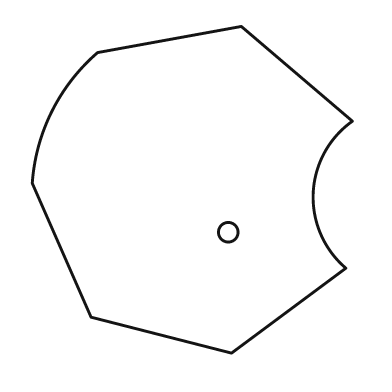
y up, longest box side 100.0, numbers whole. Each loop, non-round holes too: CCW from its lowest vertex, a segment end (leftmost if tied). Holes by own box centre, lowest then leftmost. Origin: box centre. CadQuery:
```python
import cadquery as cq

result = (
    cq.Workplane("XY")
    .moveTo(12.0, -50.0)
    .lineTo(47.0, -24.0)
    .threePointArc((37.0, -1.0), (49.0, 21.0))
    .lineTo(15.0, 50.0)
    .lineTo(-29.0, 42.0)
    .threePointArc((-43.0, 24.0), (-49.0, 2.0))
    .lineTo(-31.0, -39.0)
    .close()
    .moveTo(11.0, -13.0)
    .circle(3.0)
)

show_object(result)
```